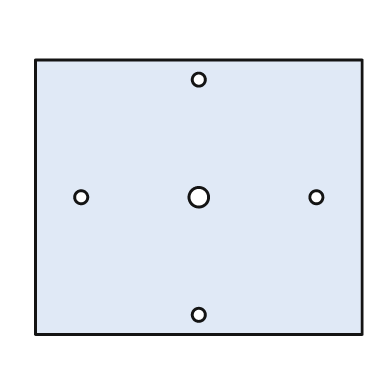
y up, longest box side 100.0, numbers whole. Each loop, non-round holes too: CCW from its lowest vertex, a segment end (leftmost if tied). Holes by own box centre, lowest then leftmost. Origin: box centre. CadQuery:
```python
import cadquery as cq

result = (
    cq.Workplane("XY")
    .moveTo(-50.0, -42.0)
    .lineTo(50.0, -42.0)
    .lineTo(50.0, 42.0)
    .lineTo(-50.0, 42.0)
    .close()
    .moveTo(0.0, -36.0)
    .circle(2.0)
    .moveTo(-36.0, 0.0)
    .circle(2.0)
    .moveTo(0.0, 0.0)
    .circle(3.0)
    .moveTo(36.0, 0.0)
    .circle(2.0)
    .moveTo(0.0, 36.0)
    .circle(2.0)
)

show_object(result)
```